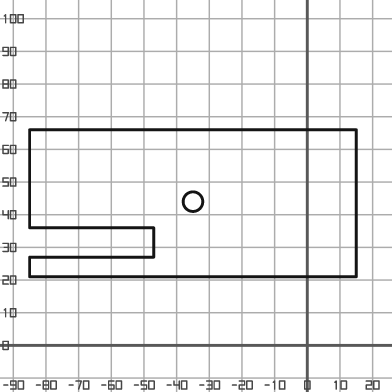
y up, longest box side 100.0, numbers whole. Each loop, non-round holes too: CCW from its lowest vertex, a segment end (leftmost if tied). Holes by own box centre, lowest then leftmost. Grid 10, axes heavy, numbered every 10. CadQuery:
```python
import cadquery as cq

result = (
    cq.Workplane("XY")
    .moveTo(-85.0, 21.0)
    .lineTo(15.0, 21.0)
    .lineTo(15.0, 66.0)
    .lineTo(-85.0, 66.0)
    .lineTo(-85.0, 36.0)
    .lineTo(-47.0, 36.0)
    .lineTo(-47.0, 27.0)
    .lineTo(-85.0, 27.0)
    .close()
    .moveTo(-35.0, 44.0)
    .circle(3.0)
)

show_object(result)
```